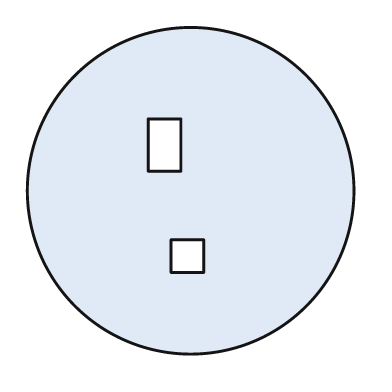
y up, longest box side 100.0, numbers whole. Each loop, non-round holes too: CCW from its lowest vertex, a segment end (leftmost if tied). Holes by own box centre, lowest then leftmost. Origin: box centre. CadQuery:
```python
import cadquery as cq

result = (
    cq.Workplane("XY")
    .moveTo(0.0, 0.0)
    .circle(50.0)
    .moveTo(-6.0, -25.0)
    .lineTo(4.0, -25.0)
    .lineTo(4.0, -15.0)
    .lineTo(-6.0, -15.0)
    .close()
    .moveTo(-13.0, 6.0)
    .lineTo(-3.0, 6.0)
    .lineTo(-3.0, 22.0)
    .lineTo(-13.0, 22.0)
    .close()
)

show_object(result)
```